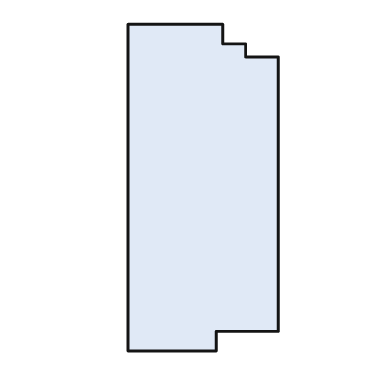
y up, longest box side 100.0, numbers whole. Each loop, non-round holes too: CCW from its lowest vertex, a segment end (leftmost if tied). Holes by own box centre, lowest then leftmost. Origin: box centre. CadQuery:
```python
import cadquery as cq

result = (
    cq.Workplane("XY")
    .moveTo(-23.0, -50.0)
    .lineTo(4.0, -50.0)
    .lineTo(4.0, -44.0)
    .lineTo(23.0, -44.0)
    .lineTo(23.0, 40.0)
    .lineTo(13.0, 40.0)
    .lineTo(13.0, 44.0)
    .lineTo(6.0, 44.0)
    .lineTo(6.0, 50.0)
    .lineTo(-23.0, 50.0)
    .close()
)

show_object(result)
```